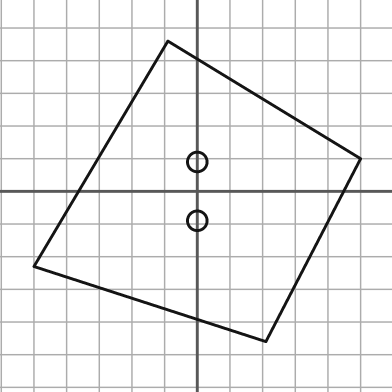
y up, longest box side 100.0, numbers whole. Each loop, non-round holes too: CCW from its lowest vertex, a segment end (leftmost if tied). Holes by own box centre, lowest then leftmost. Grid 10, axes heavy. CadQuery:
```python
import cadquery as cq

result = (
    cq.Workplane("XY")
    .moveTo(21.0, -46.0)
    .lineTo(50.0, 10.0)
    .lineTo(-9.0, 46.0)
    .lineTo(-50.0, -23.0)
    .close()
    .moveTo(0.0, -9.0)
    .circle(3.0)
    .moveTo(0.0, 9.0)
    .circle(3.0)
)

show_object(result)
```